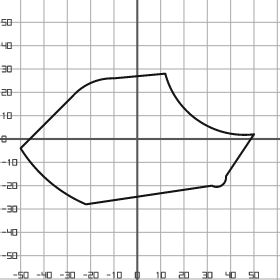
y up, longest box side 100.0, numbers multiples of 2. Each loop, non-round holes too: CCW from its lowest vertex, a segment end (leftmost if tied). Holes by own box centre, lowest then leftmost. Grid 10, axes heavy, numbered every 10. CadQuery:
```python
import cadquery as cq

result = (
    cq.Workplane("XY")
    .moveTo(-22.0, -28.0)
    .lineTo(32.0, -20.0)
    .threePointArc((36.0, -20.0), (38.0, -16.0))
    .lineTo(50.0, 2.0)
    .threePointArc((26.0, 8.0), (12.0, 28.0))
    .lineTo(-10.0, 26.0)
    .threePointArc((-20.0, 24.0), (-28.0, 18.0))
    .lineTo(-50.0, -4.0)
    .threePointArc((-38.0, -18.0), (-22.0, -28.0))
    .close()
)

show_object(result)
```